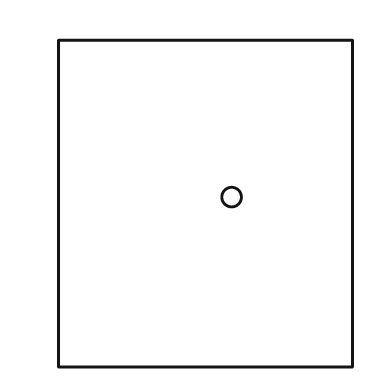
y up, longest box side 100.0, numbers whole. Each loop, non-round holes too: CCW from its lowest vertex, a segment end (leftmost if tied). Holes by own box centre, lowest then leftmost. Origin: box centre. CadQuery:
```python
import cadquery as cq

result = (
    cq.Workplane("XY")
    .moveTo(-45.0, -50.0)
    .lineTo(45.0, -50.0)
    .lineTo(45.0, 50.0)
    .lineTo(-45.0, 50.0)
    .close()
    .moveTo(8.0, 2.0)
    .circle(3.0)
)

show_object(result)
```